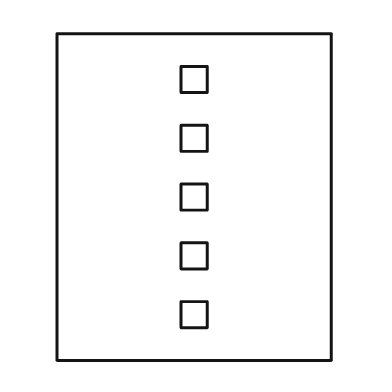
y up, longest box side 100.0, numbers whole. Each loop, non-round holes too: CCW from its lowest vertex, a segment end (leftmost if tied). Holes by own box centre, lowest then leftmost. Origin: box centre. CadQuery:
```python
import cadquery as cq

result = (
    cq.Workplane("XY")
    .moveTo(-42.0, -50.0)
    .lineTo(42.0, -50.0)
    .lineTo(42.0, 50.0)
    .lineTo(-42.0, 50.0)
    .close()
    .moveTo(-4.0, -40.0)
    .lineTo(4.0, -40.0)
    .lineTo(4.0, -32.0)
    .lineTo(-4.0, -32.0)
    .close()
    .moveTo(-4.0, -22.0)
    .lineTo(4.0, -22.0)
    .lineTo(4.0, -14.0)
    .lineTo(-4.0, -14.0)
    .close()
    .moveTo(-4.0, -4.0)
    .lineTo(4.0, -4.0)
    .lineTo(4.0, 4.0)
    .lineTo(-4.0, 4.0)
    .close()
    .moveTo(-4.0, 14.0)
    .lineTo(4.0, 14.0)
    .lineTo(4.0, 22.0)
    .lineTo(-4.0, 22.0)
    .close()
    .moveTo(-4.0, 32.0)
    .lineTo(4.0, 32.0)
    .lineTo(4.0, 40.0)
    .lineTo(-4.0, 40.0)
    .close()
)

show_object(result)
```